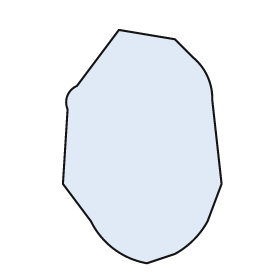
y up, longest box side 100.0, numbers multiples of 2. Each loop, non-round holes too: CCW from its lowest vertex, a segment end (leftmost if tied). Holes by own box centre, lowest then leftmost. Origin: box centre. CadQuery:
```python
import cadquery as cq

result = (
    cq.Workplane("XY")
    .moveTo(2.0, -50.0)
    .lineTo(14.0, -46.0)
    .threePointArc((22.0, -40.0), (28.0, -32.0))
    .lineTo(34.0, -16.0)
    .lineTo(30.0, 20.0)
    .threePointArc((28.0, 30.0), (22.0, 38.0))
    .lineTo(14.0, 46.0)
    .lineTo(-10.0, 50.0)
    .lineTo(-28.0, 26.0)
    .threePointArc((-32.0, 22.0), (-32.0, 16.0))
    .lineTo(-34.0, -16.0)
    .lineTo(-22.0, -32.0)
    .threePointArc((-12.0, -44.0), (2.0, -50.0))
    .close()
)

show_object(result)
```